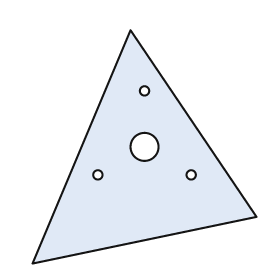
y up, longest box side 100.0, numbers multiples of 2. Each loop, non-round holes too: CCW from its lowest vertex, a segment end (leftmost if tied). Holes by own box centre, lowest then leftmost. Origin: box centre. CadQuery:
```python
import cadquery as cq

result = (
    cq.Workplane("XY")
    .moveTo(-48.0, -50.0)
    .lineTo(48.0, -30.0)
    .lineTo(-6.0, 50.0)
    .close()
    .moveTo(-20.0, -12.0)
    .circle(2.0)
    .moveTo(20.0, -12.0)
    .circle(2.0)
    .moveTo(0.0, 0.0)
    .circle(6.0)
    .moveTo(0.0, 24.0)
    .circle(2.0)
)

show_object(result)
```